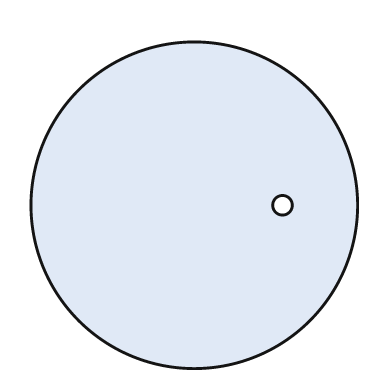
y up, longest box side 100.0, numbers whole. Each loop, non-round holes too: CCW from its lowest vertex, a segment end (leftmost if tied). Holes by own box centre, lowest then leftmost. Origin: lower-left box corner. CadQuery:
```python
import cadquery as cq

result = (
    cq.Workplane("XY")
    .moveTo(50.0, 50.0)
    .circle(50.0)
    .moveTo(77.0, 50.0)
    .circle(3.0)
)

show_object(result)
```